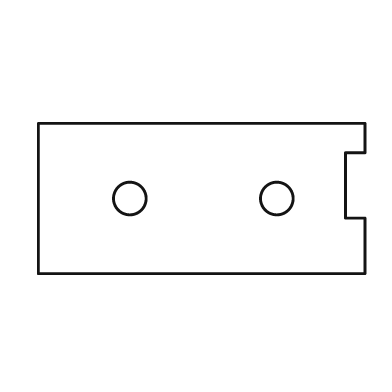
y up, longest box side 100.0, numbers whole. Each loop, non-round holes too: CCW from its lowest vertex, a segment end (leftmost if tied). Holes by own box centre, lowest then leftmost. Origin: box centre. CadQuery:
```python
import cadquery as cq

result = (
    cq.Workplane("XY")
    .moveTo(-50.0, -23.0)
    .lineTo(50.0, -23.0)
    .lineTo(50.0, -6.0)
    .lineTo(44.0, -6.0)
    .lineTo(44.0, 14.0)
    .lineTo(50.0, 14.0)
    .lineTo(50.0, 23.0)
    .lineTo(-50.0, 23.0)
    .close()
    .moveTo(-22.0, 0.0)
    .circle(5.0)
    .moveTo(23.0, 0.0)
    .circle(5.0)
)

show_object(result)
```